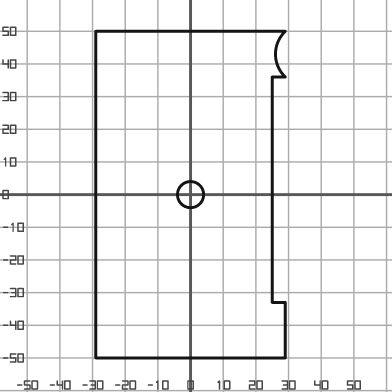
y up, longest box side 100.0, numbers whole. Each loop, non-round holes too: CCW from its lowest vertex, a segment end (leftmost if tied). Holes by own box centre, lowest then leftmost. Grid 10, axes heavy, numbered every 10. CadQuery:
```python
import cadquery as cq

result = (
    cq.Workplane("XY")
    .moveTo(-29.0, -50.0)
    .lineTo(29.0, -50.0)
    .lineTo(29.0, -33.0)
    .lineTo(25.0, -33.0)
    .lineTo(25.0, 36.0)
    .lineTo(29.0, 36.0)
    .threePointArc((26.0, 43.0), (29.0, 50.0))
    .lineTo(-29.0, 50.0)
    .close()
    .moveTo(0.0, 0.0)
    .circle(4.0)
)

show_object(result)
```